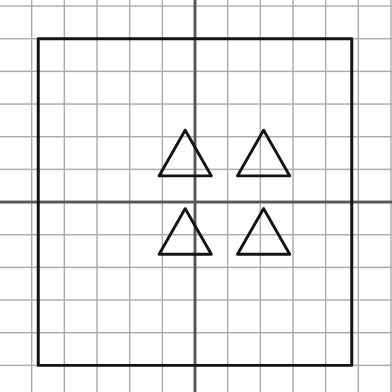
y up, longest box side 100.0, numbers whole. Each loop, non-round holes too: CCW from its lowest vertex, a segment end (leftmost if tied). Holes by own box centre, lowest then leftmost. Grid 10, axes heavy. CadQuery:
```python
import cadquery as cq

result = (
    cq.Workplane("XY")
    .moveTo(-48.0, -50.0)
    .lineTo(48.0, -50.0)
    .lineTo(48.0, 50.0)
    .lineTo(-48.0, 50.0)
    .close()
    .moveTo(-11.0, -16.0)
    .lineTo(5.0, -16.0)
    .lineTo(-3.0, -2.0)
    .close()
    .moveTo(13.0, -16.0)
    .lineTo(29.0, -16.0)
    .lineTo(21.0, -2.0)
    .close()
    .moveTo(-11.0, 8.0)
    .lineTo(5.0, 8.0)
    .lineTo(-3.0, 22.0)
    .close()
    .moveTo(13.0, 8.0)
    .lineTo(29.0, 8.0)
    .lineTo(21.0, 22.0)
    .close()
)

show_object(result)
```